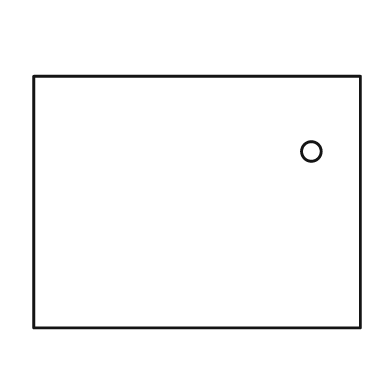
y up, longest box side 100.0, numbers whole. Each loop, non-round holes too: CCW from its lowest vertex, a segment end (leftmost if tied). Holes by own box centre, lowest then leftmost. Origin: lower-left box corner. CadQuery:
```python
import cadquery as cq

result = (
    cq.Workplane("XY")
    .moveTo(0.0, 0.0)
    .lineTo(100.0, 0.0)
    .lineTo(100.0, 77.0)
    .lineTo(0.0, 77.0)
    .close()
    .moveTo(85.0, 54.0)
    .circle(3.0)
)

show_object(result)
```